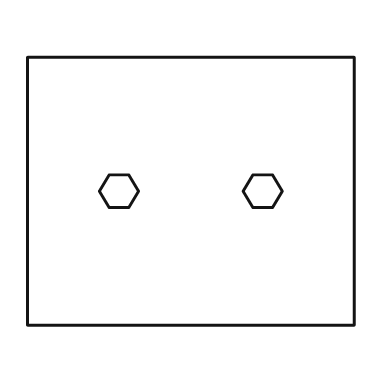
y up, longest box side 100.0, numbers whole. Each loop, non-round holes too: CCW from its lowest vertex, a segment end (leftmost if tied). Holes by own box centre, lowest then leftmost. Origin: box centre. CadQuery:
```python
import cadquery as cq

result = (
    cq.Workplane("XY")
    .moveTo(-50.0, -41.0)
    .lineTo(50.0, -41.0)
    .lineTo(50.0, 41.0)
    .lineTo(-50.0, 41.0)
    .close()
    .moveTo(-25.0, -5.0)
    .lineTo(-19.0, -5.0)
    .lineTo(-16.0, 0.0)
    .lineTo(-19.0, 5.0)
    .lineTo(-25.0, 5.0)
    .lineTo(-28.0, 0.0)
    .close()
    .moveTo(19.0, -5.0)
    .lineTo(25.0, -5.0)
    .lineTo(28.0, 0.0)
    .lineTo(25.0, 5.0)
    .lineTo(19.0, 5.0)
    .lineTo(16.0, 0.0)
    .close()
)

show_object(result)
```